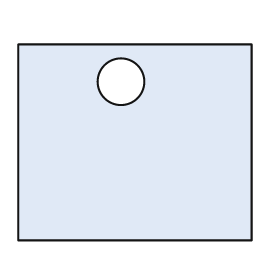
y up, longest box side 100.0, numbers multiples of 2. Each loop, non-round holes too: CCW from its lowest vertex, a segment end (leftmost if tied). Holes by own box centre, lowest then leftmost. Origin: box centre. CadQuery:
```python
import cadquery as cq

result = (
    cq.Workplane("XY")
    .moveTo(-50.0, -42.0)
    .lineTo(50.0, -42.0)
    .lineTo(50.0, 42.0)
    .lineTo(-50.0, 42.0)
    .close()
    .moveTo(-6.0, 26.0)
    .circle(10.0)
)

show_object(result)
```